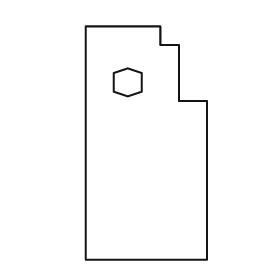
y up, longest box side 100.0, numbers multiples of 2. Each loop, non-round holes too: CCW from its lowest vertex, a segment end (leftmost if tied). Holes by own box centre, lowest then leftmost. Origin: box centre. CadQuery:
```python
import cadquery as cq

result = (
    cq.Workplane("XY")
    .moveTo(-26.0, -50.0)
    .lineTo(26.0, -50.0)
    .lineTo(26.0, 18.0)
    .lineTo(14.0, 18.0)
    .lineTo(14.0, 42.0)
    .lineTo(6.0, 42.0)
    .lineTo(6.0, 50.0)
    .lineTo(-26.0, 50.0)
    .close()
    .moveTo(-8.0, 20.0)
    .lineTo(-2.0, 22.0)
    .lineTo(-2.0, 30.0)
    .lineTo(-8.0, 32.0)
    .lineTo(-14.0, 30.0)
    .lineTo(-14.0, 22.0)
    .close()
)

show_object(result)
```